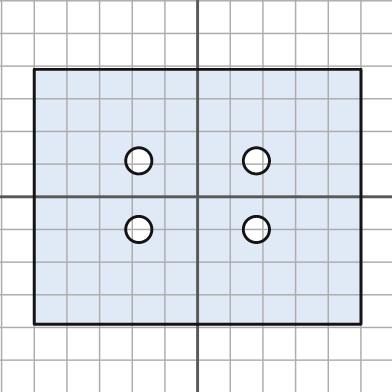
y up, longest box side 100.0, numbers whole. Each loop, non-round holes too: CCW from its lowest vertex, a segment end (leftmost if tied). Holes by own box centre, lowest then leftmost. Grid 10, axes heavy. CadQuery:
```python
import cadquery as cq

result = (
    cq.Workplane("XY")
    .moveTo(-50.0, -39.0)
    .lineTo(50.0, -39.0)
    .lineTo(50.0, 39.0)
    .lineTo(-50.0, 39.0)
    .close()
    .moveTo(-18.0, -10.0)
    .circle(4.0)
    .moveTo(18.0, -10.0)
    .circle(4.0)
    .moveTo(-18.0, 11.0)
    .circle(4.0)
    .moveTo(18.0, 11.0)
    .circle(4.0)
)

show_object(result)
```